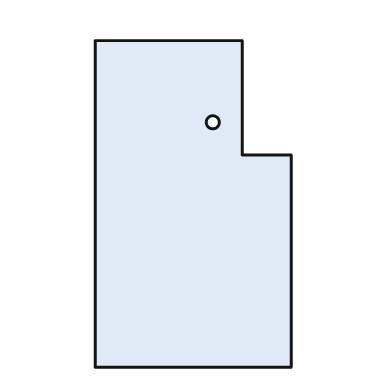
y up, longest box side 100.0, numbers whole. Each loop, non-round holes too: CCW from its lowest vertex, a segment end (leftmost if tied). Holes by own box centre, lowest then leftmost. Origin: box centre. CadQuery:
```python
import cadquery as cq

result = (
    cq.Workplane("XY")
    .moveTo(-30.0, -50.0)
    .lineTo(30.0, -50.0)
    .lineTo(30.0, 15.0)
    .lineTo(15.0, 15.0)
    .lineTo(15.0, 50.0)
    .lineTo(-30.0, 50.0)
    .close()
    .moveTo(6.0, 25.0)
    .circle(2.0)
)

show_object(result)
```